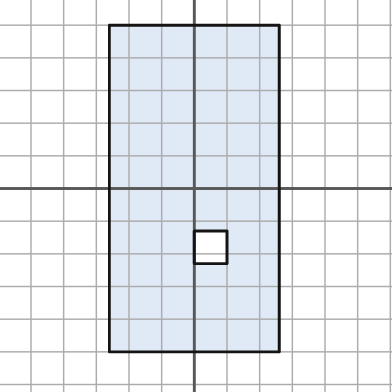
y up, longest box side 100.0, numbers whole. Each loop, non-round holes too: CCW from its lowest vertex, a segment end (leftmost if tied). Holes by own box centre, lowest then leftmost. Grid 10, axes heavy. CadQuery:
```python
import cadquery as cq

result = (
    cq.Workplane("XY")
    .moveTo(-26.0, -50.0)
    .lineTo(26.0, -50.0)
    .lineTo(26.0, 50.0)
    .lineTo(-26.0, 50.0)
    .close()
    .moveTo(0.0, -23.0)
    .lineTo(10.0, -23.0)
    .lineTo(10.0, -13.0)
    .lineTo(0.0, -13.0)
    .close()
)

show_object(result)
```